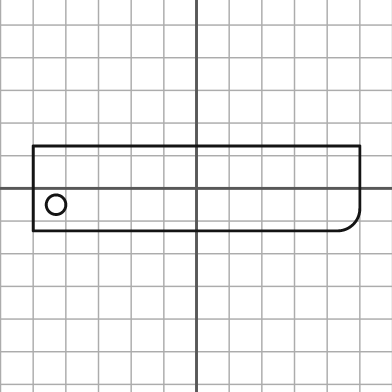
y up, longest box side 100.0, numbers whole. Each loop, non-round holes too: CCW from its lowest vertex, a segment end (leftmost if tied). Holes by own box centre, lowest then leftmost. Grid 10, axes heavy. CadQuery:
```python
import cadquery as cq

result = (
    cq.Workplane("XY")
    .moveTo(-50.0, -13.0)
    .lineTo(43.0, -13.0)
    .threePointArc((48.0, -11.0), (50.0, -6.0))
    .lineTo(50.0, 13.0)
    .lineTo(-50.0, 13.0)
    .close()
    .moveTo(-43.0, -5.0)
    .circle(3.0)
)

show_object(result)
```